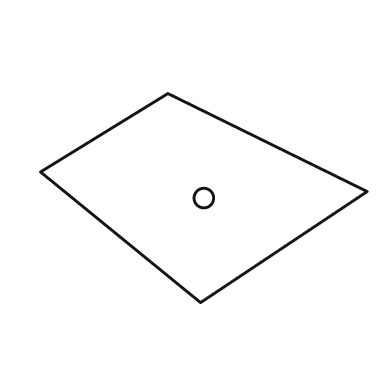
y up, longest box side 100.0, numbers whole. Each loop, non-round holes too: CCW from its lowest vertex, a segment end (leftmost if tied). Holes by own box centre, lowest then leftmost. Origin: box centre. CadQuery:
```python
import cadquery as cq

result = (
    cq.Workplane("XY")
    .moveTo(-1.0, -32.0)
    .lineTo(50.0, 2.0)
    .lineTo(-11.0, 32.0)
    .lineTo(-50.0, 8.0)
    .close()
    .moveTo(0.0, 0.0)
    .circle(3.0)
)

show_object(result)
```